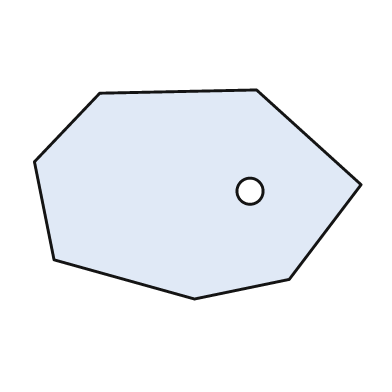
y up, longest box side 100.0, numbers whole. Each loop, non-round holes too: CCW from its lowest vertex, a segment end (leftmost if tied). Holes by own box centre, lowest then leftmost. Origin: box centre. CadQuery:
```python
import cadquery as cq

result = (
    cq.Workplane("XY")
    .moveTo(-1.0, -32.0)
    .lineTo(28.0, -26.0)
    .lineTo(50.0, 3.0)
    .lineTo(18.0, 32.0)
    .lineTo(-30.0, 31.0)
    .lineTo(-50.0, 10.0)
    .lineTo(-44.0, -20.0)
    .close()
    .moveTo(16.0, 1.0)
    .circle(4.0)
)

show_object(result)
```